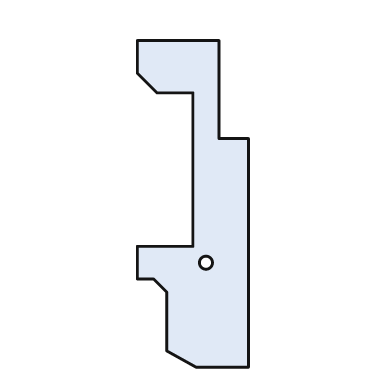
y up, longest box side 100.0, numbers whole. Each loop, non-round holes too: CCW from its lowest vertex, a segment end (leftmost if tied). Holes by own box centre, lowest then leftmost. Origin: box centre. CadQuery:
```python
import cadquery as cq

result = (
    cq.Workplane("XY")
    .moveTo(1.0, -50.0)
    .lineTo(17.0, -50.0)
    .lineTo(17.0, 20.0)
    .lineTo(8.0, 20.0)
    .lineTo(8.0, 50.0)
    .lineTo(-17.0, 50.0)
    .lineTo(-17.0, 40.0)
    .lineTo(-11.0, 34.0)
    .lineTo(0.0, 34.0)
    .lineTo(0.0, -13.0)
    .lineTo(-17.0, -13.0)
    .lineTo(-17.0, -23.0)
    .lineTo(-12.0, -23.0)
    .lineTo(-8.0, -27.0)
    .lineTo(-8.0, -45.0)
    .close()
    .moveTo(4.0, -18.0)
    .circle(2.0)
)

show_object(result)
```